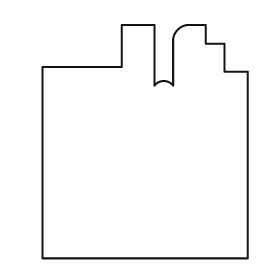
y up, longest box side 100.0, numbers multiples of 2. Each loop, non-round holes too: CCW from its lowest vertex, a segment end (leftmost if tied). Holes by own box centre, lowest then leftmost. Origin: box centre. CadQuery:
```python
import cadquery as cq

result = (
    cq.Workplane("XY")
    .moveTo(-44.0, -50.0)
    .lineTo(44.0, -50.0)
    .lineTo(44.0, 30.0)
    .lineTo(34.0, 30.0)
    .lineTo(34.0, 42.0)
    .lineTo(26.0, 42.0)
    .lineTo(26.0, 50.0)
    .lineTo(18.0, 50.0)
    .threePointArc((14.0, 48.0), (12.0, 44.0))
    .lineTo(12.0, 24.0)
    .threePointArc((8.0, 26.0), (4.0, 24.0))
    .lineTo(4.0, 50.0)
    .lineTo(-10.0, 50.0)
    .lineTo(-10.0, 32.0)
    .lineTo(-44.0, 32.0)
    .close()
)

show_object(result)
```